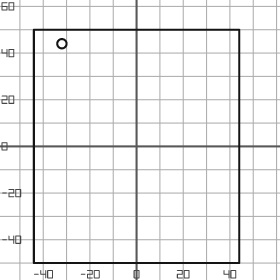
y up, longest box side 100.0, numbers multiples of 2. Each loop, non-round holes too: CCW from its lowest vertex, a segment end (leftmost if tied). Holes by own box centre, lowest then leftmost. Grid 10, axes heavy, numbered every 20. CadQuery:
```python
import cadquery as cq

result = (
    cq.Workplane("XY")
    .moveTo(-44.0, -50.0)
    .lineTo(44.0, -50.0)
    .lineTo(44.0, 50.0)
    .lineTo(-44.0, 50.0)
    .close()
    .moveTo(-32.0, 44.0)
    .circle(2.0)
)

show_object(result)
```